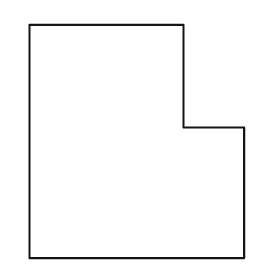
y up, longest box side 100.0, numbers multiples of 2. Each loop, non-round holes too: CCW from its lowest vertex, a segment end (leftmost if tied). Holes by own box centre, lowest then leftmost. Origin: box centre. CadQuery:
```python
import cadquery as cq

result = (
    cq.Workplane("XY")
    .moveTo(-46.0, -50.0)
    .lineTo(46.0, -50.0)
    .lineTo(46.0, 6.0)
    .lineTo(20.0, 6.0)
    .lineTo(20.0, 50.0)
    .lineTo(-46.0, 50.0)
    .close()
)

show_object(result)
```